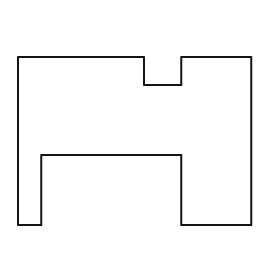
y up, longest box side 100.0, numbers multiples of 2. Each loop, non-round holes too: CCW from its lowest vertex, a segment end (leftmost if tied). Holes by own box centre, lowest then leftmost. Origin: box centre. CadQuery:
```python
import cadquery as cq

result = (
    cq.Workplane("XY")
    .moveTo(-50.0, -36.0)
    .lineTo(-40.0, -36.0)
    .lineTo(-40.0, -6.0)
    .lineTo(20.0, -6.0)
    .lineTo(20.0, -36.0)
    .lineTo(50.0, -36.0)
    .lineTo(50.0, 36.0)
    .lineTo(20.0, 36.0)
    .lineTo(20.0, 24.0)
    .lineTo(4.0, 24.0)
    .lineTo(4.0, 36.0)
    .lineTo(-50.0, 36.0)
    .close()
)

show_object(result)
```